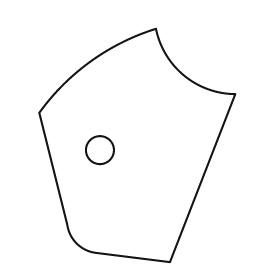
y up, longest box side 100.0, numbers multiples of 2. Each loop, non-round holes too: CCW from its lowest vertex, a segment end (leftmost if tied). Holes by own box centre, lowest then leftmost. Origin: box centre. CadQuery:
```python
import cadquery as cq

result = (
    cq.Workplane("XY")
    .moveTo(14.0, -50.0)
    .lineTo(42.0, 22.0)
    .threePointArc((20.0, 30.0), (8.0, 50.0))
    .threePointArc((-20.0, 36.0), (-42.0, 14.0))
    .lineTo(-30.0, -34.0)
    .threePointArc((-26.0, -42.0), (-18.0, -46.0))
    .close()
    .moveTo(-16.0, -2.0)
    .circle(6.0)
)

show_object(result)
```